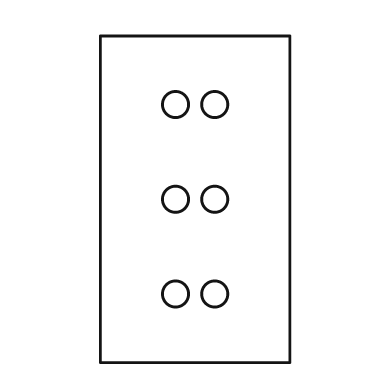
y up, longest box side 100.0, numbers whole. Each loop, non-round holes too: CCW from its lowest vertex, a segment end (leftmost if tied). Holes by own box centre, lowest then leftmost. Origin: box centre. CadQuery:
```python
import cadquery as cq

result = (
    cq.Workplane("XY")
    .moveTo(-29.0, -50.0)
    .lineTo(29.0, -50.0)
    .lineTo(29.0, 50.0)
    .lineTo(-29.0, 50.0)
    .close()
    .moveTo(-6.0, -29.0)
    .circle(4.0)
    .moveTo(6.0, -29.0)
    .circle(4.0)
    .moveTo(-6.0, 0.0)
    .circle(4.0)
    .moveTo(6.0, 0.0)
    .circle(4.0)
    .moveTo(-6.0, 29.0)
    .circle(4.0)
    .moveTo(6.0, 29.0)
    .circle(4.0)
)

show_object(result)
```